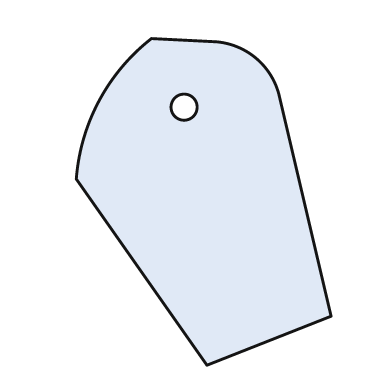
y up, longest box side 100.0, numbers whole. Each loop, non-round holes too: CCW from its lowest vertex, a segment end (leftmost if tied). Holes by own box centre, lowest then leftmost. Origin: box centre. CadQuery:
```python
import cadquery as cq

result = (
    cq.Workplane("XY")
    .moveTo(1.0, -50.0)
    .lineTo(39.0, -35.0)
    .lineTo(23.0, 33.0)
    .threePointArc((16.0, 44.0), (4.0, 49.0))
    .lineTo(-16.0, 50.0)
    .threePointArc((-32.0, 31.0), (-39.0, 7.0))
    .close()
    .moveTo(-6.0, 29.0)
    .circle(4.0)
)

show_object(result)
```